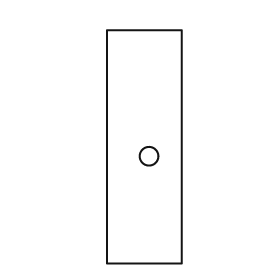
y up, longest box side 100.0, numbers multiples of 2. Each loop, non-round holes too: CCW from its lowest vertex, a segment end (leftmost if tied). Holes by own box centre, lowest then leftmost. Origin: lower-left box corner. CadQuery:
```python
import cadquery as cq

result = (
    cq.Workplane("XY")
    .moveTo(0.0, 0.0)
    .lineTo(32.0, 0.0)
    .lineTo(32.0, 100.0)
    .lineTo(0.0, 100.0)
    .close()
    .moveTo(18.0, 46.0)
    .circle(4.0)
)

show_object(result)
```